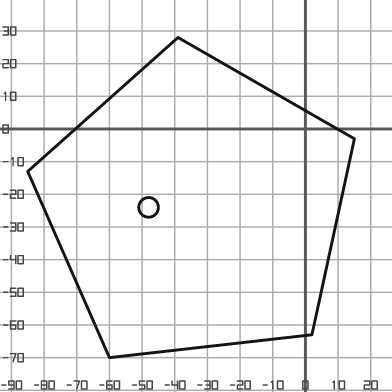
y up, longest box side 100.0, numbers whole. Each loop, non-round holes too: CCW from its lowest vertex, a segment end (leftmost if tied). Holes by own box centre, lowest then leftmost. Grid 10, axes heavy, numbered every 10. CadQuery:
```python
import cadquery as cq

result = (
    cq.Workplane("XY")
    .moveTo(-60.0, -70.0)
    .lineTo(2.0, -63.0)
    .lineTo(15.0, -3.0)
    .lineTo(-39.0, 28.0)
    .lineTo(-85.0, -13.0)
    .close()
    .moveTo(-48.0, -24.0)
    .circle(3.0)
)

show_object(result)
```